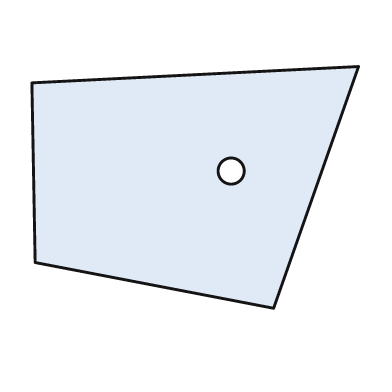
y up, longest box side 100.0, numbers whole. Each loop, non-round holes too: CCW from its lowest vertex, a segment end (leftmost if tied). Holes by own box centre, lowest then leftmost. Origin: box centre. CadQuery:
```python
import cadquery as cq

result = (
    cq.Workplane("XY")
    .moveTo(24.0, -37.0)
    .lineTo(50.0, 37.0)
    .lineTo(-50.0, 32.0)
    .lineTo(-49.0, -23.0)
    .close()
    .moveTo(11.0, 5.0)
    .circle(4.0)
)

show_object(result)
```